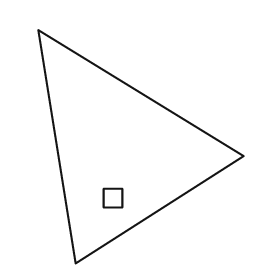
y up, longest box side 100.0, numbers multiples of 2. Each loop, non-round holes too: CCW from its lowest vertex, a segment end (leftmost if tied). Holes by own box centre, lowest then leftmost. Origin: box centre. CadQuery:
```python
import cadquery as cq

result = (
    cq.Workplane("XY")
    .moveTo(-28.0, -50.0)
    .lineTo(44.0, -4.0)
    .lineTo(-44.0, 50.0)
    .close()
    .moveTo(-16.0, -26.0)
    .lineTo(-8.0, -26.0)
    .lineTo(-8.0, -18.0)
    .lineTo(-16.0, -18.0)
    .close()
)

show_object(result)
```